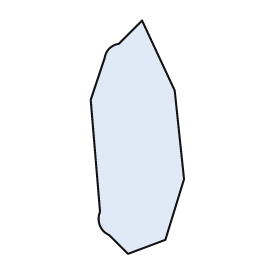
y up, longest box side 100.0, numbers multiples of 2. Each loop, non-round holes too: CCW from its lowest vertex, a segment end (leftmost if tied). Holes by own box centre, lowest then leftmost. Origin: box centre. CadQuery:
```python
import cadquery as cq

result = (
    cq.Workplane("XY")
    .moveTo(-4.0, -50.0)
    .lineTo(12.0, -44.0)
    .lineTo(20.0, -18.0)
    .lineTo(16.0, 20.0)
    .lineTo(2.0, 50.0)
    .lineTo(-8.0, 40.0)
    .threePointArc((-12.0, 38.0), (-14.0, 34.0))
    .lineTo(-20.0, 16.0)
    .lineTo(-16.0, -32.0)
    .threePointArc((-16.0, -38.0), (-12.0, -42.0))
    .close()
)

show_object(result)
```